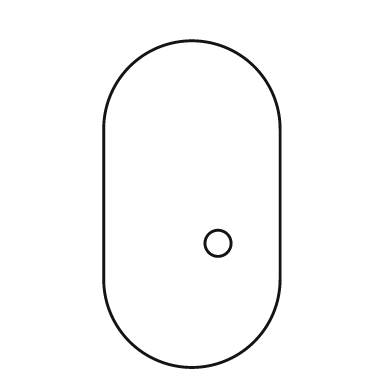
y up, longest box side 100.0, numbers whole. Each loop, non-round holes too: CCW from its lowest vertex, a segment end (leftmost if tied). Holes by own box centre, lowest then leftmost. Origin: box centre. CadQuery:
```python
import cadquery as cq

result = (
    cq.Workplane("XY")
    .moveTo(-27.0, -23.0)
    .threePointArc((0.0, -50.0), (27.0, -23.0))
    .lineTo(27.0, 23.0)
    .threePointArc((0.0, 50.0), (-27.0, 23.0))
    .close()
    .moveTo(8.0, -12.0)
    .circle(4.0)
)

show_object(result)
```